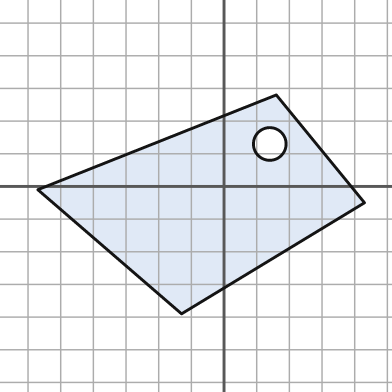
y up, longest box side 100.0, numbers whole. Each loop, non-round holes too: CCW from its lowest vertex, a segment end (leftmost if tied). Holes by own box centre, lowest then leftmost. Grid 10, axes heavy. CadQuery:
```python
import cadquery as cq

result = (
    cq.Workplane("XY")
    .moveTo(-13.0, -39.0)
    .lineTo(43.0, -5.0)
    .lineTo(16.0, 28.0)
    .lineTo(-57.0, -1.0)
    .close()
    .moveTo(14.0, 13.0)
    .circle(5.0)
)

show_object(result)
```